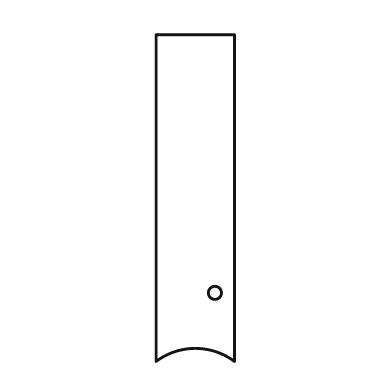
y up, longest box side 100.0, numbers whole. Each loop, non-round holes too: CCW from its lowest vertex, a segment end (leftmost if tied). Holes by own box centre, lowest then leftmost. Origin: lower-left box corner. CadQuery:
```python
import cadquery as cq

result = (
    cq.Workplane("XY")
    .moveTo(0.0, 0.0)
    .threePointArc((12.0, 4.0), (24.0, 0.0))
    .lineTo(24.0, 100.0)
    .lineTo(0.0, 100.0)
    .close()
    .moveTo(18.0, 21.0)
    .circle(2.0)
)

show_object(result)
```